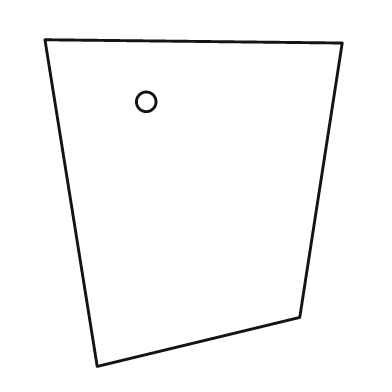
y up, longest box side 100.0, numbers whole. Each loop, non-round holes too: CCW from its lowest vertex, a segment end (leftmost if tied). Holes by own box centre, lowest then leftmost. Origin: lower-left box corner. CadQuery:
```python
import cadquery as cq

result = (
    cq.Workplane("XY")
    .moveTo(16.0, 0.0)
    .lineTo(78.0, 15.0)
    .lineTo(91.0, 99.0)
    .lineTo(0.0, 100.0)
    .close()
    .moveTo(31.0, 81.0)
    .circle(3.0)
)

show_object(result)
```